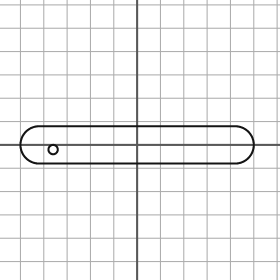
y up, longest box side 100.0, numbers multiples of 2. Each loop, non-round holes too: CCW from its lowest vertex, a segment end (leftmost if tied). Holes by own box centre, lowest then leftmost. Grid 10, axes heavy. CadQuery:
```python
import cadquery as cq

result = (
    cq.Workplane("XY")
    .moveTo(-42.0, -8.0)
    .lineTo(42.0, -8.0)
    .threePointArc((50.0, 0.0), (42.0, 8.0))
    .lineTo(-42.0, 8.0)
    .threePointArc((-50.0, 0.0), (-42.0, -8.0))
    .close()
    .moveTo(-36.0, -2.0)
    .circle(2.0)
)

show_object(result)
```